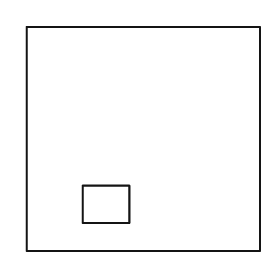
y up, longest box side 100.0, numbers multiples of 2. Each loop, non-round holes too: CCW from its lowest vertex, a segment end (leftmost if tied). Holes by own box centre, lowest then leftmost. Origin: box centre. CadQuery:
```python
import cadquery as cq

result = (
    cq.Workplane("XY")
    .moveTo(-50.0, -48.0)
    .lineTo(50.0, -48.0)
    .lineTo(50.0, 48.0)
    .lineTo(-50.0, 48.0)
    .close()
    .moveTo(-26.0, -36.0)
    .lineTo(-6.0, -36.0)
    .lineTo(-6.0, -20.0)
    .lineTo(-26.0, -20.0)
    .close()
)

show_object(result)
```